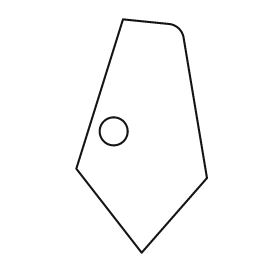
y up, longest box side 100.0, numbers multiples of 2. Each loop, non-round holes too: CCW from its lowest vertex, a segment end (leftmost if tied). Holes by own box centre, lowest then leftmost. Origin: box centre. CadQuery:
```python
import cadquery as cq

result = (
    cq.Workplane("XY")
    .moveTo(0.0, -50.0)
    .lineTo(28.0, -18.0)
    .lineTo(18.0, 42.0)
    .threePointArc((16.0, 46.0), (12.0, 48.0))
    .lineTo(-8.0, 50.0)
    .lineTo(-28.0, -14.0)
    .close()
    .moveTo(-12.0, 2.0)
    .circle(6.0)
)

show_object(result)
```